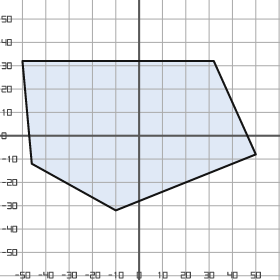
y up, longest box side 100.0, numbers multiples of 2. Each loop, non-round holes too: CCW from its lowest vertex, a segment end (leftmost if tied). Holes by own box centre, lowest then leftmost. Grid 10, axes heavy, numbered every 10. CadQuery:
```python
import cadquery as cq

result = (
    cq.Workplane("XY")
    .moveTo(-10.0, -32.0)
    .lineTo(50.0, -8.0)
    .lineTo(32.0, 32.0)
    .lineTo(-50.0, 32.0)
    .lineTo(-46.0, -12.0)
    .close()
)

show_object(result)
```